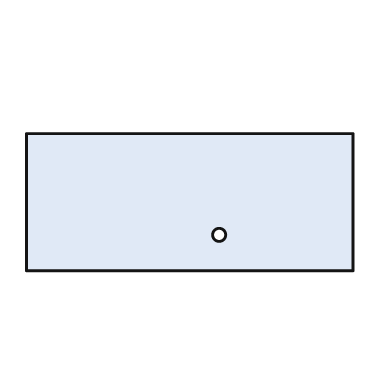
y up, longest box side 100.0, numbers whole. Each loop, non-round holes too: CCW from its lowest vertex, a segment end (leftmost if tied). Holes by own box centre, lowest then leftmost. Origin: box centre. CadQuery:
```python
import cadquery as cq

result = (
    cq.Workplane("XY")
    .moveTo(-50.0, -21.0)
    .lineTo(50.0, -21.0)
    .lineTo(50.0, 21.0)
    .lineTo(-50.0, 21.0)
    .close()
    .moveTo(9.0, -10.0)
    .circle(2.0)
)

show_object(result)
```